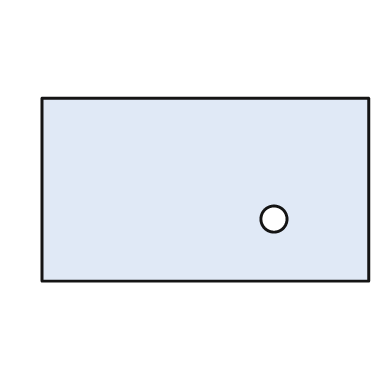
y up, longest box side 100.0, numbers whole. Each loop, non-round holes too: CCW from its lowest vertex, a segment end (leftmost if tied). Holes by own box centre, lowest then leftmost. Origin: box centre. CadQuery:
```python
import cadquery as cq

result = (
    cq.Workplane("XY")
    .moveTo(-50.0, -28.0)
    .lineTo(50.0, -28.0)
    .lineTo(50.0, 28.0)
    .lineTo(-50.0, 28.0)
    .close()
    .moveTo(21.0, -9.0)
    .circle(4.0)
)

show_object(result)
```